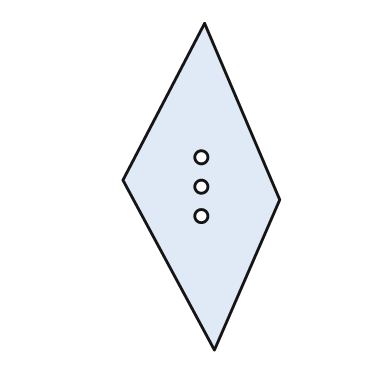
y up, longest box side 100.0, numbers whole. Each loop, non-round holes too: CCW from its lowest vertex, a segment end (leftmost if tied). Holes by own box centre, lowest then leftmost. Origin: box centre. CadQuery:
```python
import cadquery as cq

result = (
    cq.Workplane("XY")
    .moveTo(4.0, -50.0)
    .lineTo(24.0, -4.0)
    .lineTo(1.0, 50.0)
    .lineTo(-24.0, 2.0)
    .close()
    .moveTo(0.0, -9.0)
    .circle(2.0)
    .moveTo(0.0, 0.0)
    .circle(2.0)
    .moveTo(0.0, 9.0)
    .circle(2.0)
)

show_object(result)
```